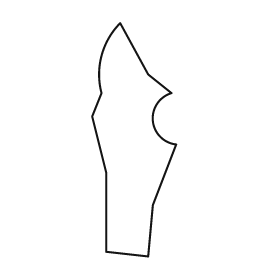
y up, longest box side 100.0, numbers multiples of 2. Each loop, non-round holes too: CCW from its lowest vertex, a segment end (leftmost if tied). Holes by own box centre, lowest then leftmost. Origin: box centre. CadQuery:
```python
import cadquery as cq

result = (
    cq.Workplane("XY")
    .moveTo(6.0, -50.0)
    .lineTo(8.0, -28.0)
    .lineTo(18.0, -2.0)
    .threePointArc((8.0, 8.0), (16.0, 20.0))
    .lineTo(6.0, 28.0)
    .lineTo(-6.0, 50.0)
    .threePointArc((-14.0, 36.0), (-14.0, 20.0))
    .lineTo(-18.0, 10.0)
    .lineTo(-12.0, -14.0)
    .lineTo(-12.0, -48.0)
    .close()
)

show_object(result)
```